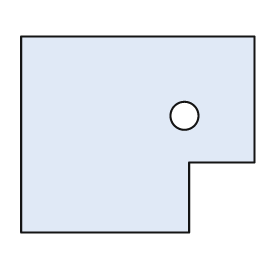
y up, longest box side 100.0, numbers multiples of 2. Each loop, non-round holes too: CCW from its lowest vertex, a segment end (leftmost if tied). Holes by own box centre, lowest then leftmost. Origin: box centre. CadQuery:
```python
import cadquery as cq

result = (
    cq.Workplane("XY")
    .moveTo(-50.0, -42.0)
    .lineTo(22.0, -42.0)
    .lineTo(22.0, -12.0)
    .lineTo(50.0, -12.0)
    .lineTo(50.0, 42.0)
    .lineTo(-50.0, 42.0)
    .close()
    .moveTo(20.0, 8.0)
    .circle(6.0)
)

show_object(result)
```